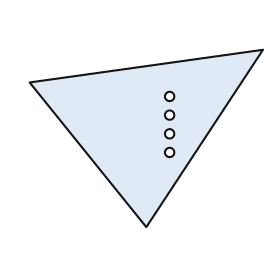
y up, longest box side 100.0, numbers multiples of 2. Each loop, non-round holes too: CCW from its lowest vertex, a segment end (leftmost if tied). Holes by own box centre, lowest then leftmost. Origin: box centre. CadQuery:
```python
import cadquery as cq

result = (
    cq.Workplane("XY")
    .moveTo(0.0, -38.0)
    .lineTo(50.0, 38.0)
    .lineTo(-50.0, 24.0)
    .close()
    .moveTo(10.0, -6.0)
    .circle(2.0)
    .moveTo(10.0, 2.0)
    .circle(2.0)
    .moveTo(10.0, 10.0)
    .circle(2.0)
    .moveTo(10.0, 18.0)
    .circle(2.0)
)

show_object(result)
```